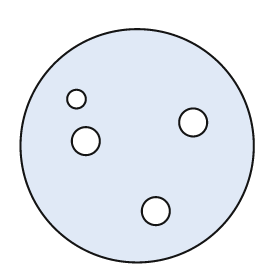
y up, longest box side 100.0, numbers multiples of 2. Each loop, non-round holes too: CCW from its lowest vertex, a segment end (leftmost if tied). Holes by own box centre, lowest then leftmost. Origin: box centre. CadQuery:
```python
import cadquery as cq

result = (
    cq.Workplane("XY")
    .moveTo(0.0, 0.0)
    .circle(50.0)
    .moveTo(8.0, -28.0)
    .circle(6.0)
    .moveTo(-22.0, 2.0)
    .circle(6.0)
    .moveTo(24.0, 10.0)
    .circle(6.0)
    .moveTo(-26.0, 20.0)
    .circle(4.0)
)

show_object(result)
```